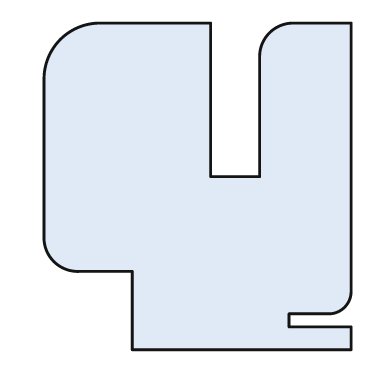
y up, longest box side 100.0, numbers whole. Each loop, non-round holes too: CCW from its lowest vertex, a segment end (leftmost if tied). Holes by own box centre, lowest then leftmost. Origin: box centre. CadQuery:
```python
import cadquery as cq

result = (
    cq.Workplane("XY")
    .moveTo(-20.0, -50.0)
    .lineTo(47.0, -50.0)
    .lineTo(47.0, -43.0)
    .lineTo(28.0, -43.0)
    .lineTo(28.0, -39.0)
    .lineTo(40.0, -39.0)
    .threePointArc((45.0, -37.0), (47.0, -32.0))
    .lineTo(47.0, 50.0)
    .lineTo(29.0, 50.0)
    .threePointArc((22.0, 47.0), (19.0, 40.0))
    .lineTo(19.0, 3.0)
    .lineTo(4.0, 3.0)
    .lineTo(4.0, 50.0)
    .lineTo(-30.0, 50.0)
    .threePointArc((-42.0, 45.0), (-47.0, 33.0))
    .lineTo(-47.0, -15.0)
    .threePointArc((-44.0, -23.0), (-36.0, -26.0))
    .lineTo(-20.0, -26.0)
    .close()
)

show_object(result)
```